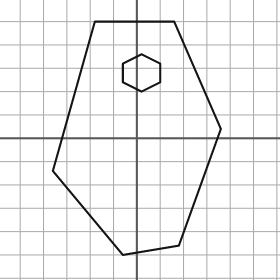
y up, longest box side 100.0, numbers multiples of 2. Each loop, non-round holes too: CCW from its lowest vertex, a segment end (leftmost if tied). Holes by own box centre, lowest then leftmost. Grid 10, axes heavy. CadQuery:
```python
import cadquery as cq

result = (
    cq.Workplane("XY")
    .moveTo(-6.0, -50.0)
    .lineTo(18.0, -46.0)
    .lineTo(36.0, 4.0)
    .lineTo(16.0, 50.0)
    .lineTo(-18.0, 50.0)
    .lineTo(-36.0, -14.0)
    .close()
    .moveTo(2.0, 20.0)
    .lineTo(10.0, 24.0)
    .lineTo(10.0, 32.0)
    .lineTo(2.0, 36.0)
    .lineTo(-6.0, 32.0)
    .lineTo(-6.0, 24.0)
    .close()
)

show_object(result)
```